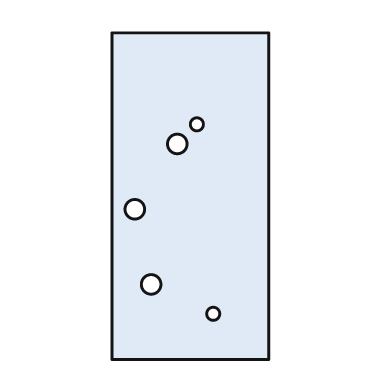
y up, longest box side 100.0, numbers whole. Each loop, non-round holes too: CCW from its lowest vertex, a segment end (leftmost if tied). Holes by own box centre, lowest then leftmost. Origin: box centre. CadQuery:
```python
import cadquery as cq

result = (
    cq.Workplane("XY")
    .moveTo(-24.0, -50.0)
    .lineTo(24.0, -50.0)
    .lineTo(24.0, 50.0)
    .lineTo(-24.0, 50.0)
    .close()
    .moveTo(7.0, -36.0)
    .circle(2.0)
    .moveTo(-12.0, -27.0)
    .circle(3.0)
    .moveTo(-17.0, -4.0)
    .circle(3.0)
    .moveTo(-4.0, 16.0)
    .circle(3.0)
    .moveTo(2.0, 22.0)
    .circle(2.0)
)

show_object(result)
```